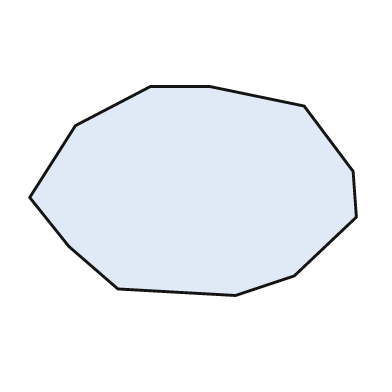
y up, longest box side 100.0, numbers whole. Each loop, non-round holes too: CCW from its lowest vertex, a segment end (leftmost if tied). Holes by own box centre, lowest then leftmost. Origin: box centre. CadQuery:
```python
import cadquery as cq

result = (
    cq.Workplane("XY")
    .moveTo(13.0, -32.0)
    .lineTo(31.0, -26.0)
    .lineTo(50.0, -8.0)
    .lineTo(49.0, 6.0)
    .lineTo(34.0, 26.0)
    .lineTo(5.0, 32.0)
    .lineTo(-13.0, 32.0)
    .lineTo(-36.0, 20.0)
    .lineTo(-50.0, -2.0)
    .lineTo(-38.0, -17.0)
    .lineTo(-23.0, -30.0)
    .close()
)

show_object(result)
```